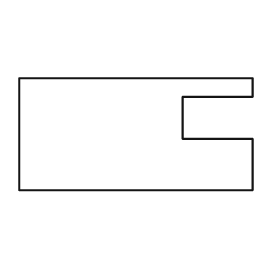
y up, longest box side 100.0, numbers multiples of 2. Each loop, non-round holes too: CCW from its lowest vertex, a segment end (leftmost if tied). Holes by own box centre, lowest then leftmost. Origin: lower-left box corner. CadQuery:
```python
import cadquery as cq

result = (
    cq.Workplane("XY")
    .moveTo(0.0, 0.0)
    .lineTo(100.0, 0.0)
    .lineTo(100.0, 22.0)
    .lineTo(70.0, 22.0)
    .lineTo(70.0, 40.0)
    .lineTo(100.0, 40.0)
    .lineTo(100.0, 48.0)
    .lineTo(0.0, 48.0)
    .close()
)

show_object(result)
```